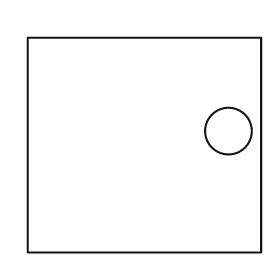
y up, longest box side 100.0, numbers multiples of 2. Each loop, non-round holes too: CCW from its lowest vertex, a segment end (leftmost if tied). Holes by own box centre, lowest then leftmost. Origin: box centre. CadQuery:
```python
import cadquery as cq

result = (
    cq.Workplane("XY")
    .moveTo(-50.0, -46.0)
    .lineTo(50.0, -46.0)
    .lineTo(50.0, 46.0)
    .lineTo(-50.0, 46.0)
    .close()
    .moveTo(36.0, 6.0)
    .circle(10.0)
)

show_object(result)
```